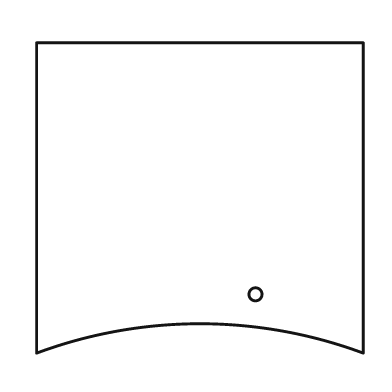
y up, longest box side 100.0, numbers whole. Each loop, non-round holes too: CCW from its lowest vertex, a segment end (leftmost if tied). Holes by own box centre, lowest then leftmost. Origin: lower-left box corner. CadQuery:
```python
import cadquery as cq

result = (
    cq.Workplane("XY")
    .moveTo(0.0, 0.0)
    .threePointArc((50.0, 9.0), (100.0, 0.0))
    .lineTo(100.0, 95.0)
    .lineTo(0.0, 95.0)
    .close()
    .moveTo(67.0, 18.0)
    .circle(2.0)
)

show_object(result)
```